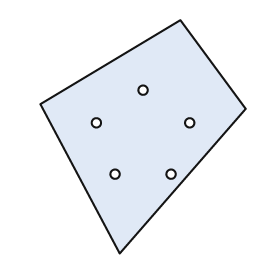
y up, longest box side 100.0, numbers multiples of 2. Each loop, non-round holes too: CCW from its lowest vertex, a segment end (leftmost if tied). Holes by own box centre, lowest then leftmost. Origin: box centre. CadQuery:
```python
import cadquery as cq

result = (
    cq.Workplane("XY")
    .moveTo(-10.0, -50.0)
    .lineTo(44.0, 12.0)
    .lineTo(16.0, 50.0)
    .lineTo(-44.0, 14.0)
    .close()
    .moveTo(-12.0, -16.0)
    .circle(2.0)
    .moveTo(12.0, -16.0)
    .circle(2.0)
    .moveTo(-20.0, 6.0)
    .circle(2.0)
    .moveTo(20.0, 6.0)
    .circle(2.0)
    .moveTo(0.0, 20.0)
    .circle(2.0)
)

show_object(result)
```